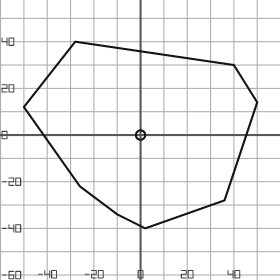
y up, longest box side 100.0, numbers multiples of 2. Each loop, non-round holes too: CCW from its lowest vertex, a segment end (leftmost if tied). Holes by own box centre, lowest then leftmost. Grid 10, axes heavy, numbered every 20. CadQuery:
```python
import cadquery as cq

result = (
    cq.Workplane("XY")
    .moveTo(2.0, -40.0)
    .lineTo(36.0, -28.0)
    .lineTo(50.0, 14.0)
    .lineTo(40.0, 30.0)
    .lineTo(-28.0, 40.0)
    .lineTo(-50.0, 12.0)
    .lineTo(-26.0, -22.0)
    .lineTo(-10.0, -34.0)
    .close()
    .moveTo(0.0, 0.0)
    .circle(2.0)
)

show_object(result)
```